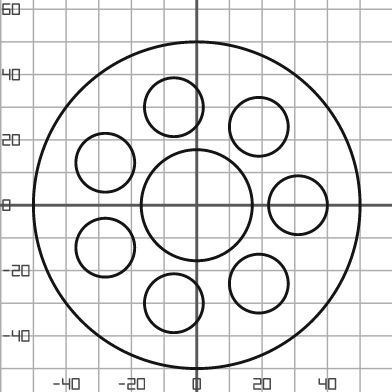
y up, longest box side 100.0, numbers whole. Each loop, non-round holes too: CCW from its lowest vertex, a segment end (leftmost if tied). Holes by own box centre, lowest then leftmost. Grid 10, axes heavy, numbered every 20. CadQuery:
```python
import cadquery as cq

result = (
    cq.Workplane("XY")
    .moveTo(0.0, 0.0)
    .circle(50.0)
    .moveTo(-7.0, -30.0)
    .circle(9.0)
    .moveTo(19.0, -24.0)
    .circle(9.0)
    .moveTo(-28.0, -13.0)
    .circle(9.0)
    .moveTo(0.0, 0.0)
    .circle(17.0)
    .moveTo(31.0, 0.0)
    .circle(9.0)
    .moveTo(-28.0, 13.0)
    .circle(9.0)
    .moveTo(19.0, 24.0)
    .circle(9.0)
    .moveTo(-7.0, 30.0)
    .circle(9.0)
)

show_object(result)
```